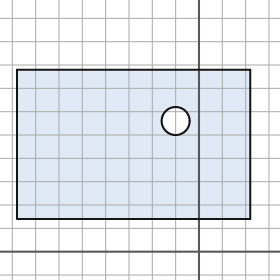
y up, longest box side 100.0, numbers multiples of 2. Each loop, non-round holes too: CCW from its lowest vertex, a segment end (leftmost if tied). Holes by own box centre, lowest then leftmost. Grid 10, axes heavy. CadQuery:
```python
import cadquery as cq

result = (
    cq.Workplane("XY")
    .moveTo(-78.0, 14.0)
    .lineTo(22.0, 14.0)
    .lineTo(22.0, 78.0)
    .lineTo(-78.0, 78.0)
    .close()
    .moveTo(-10.0, 56.0)
    .circle(6.0)
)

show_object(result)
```